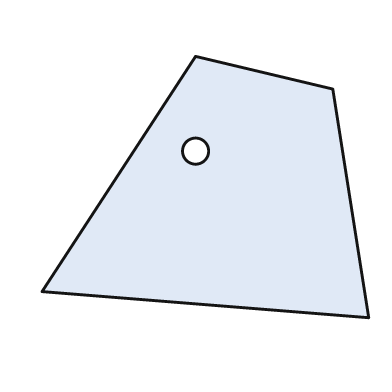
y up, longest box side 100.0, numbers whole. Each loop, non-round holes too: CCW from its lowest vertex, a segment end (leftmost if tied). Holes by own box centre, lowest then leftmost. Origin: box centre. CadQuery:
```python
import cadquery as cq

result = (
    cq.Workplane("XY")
    .moveTo(50.0, -40.0)
    .lineTo(39.0, 30.0)
    .lineTo(-3.0, 40.0)
    .lineTo(-50.0, -32.0)
    .close()
    .moveTo(-3.0, 11.0)
    .circle(4.0)
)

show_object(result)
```